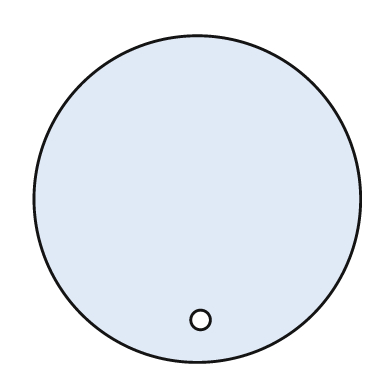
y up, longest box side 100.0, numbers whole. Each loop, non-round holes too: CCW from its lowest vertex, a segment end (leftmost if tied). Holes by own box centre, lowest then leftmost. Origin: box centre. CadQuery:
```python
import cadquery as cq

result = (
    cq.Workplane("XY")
    .moveTo(0.0, 0.0)
    .circle(50.0)
    .moveTo(1.0, -37.0)
    .circle(3.0)
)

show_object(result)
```